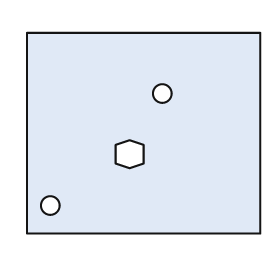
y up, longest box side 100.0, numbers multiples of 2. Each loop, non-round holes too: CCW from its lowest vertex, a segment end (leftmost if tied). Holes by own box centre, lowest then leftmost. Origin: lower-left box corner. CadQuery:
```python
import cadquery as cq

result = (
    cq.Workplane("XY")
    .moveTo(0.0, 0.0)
    .lineTo(100.0, 0.0)
    .lineTo(100.0, 86.0)
    .lineTo(0.0, 86.0)
    .close()
    .moveTo(10.0, 12.0)
    .circle(4.0)
    .moveTo(44.0, 28.0)
    .lineTo(50.0, 30.0)
    .lineTo(50.0, 38.0)
    .lineTo(44.0, 40.0)
    .lineTo(38.0, 38.0)
    .lineTo(38.0, 30.0)
    .close()
    .moveTo(58.0, 60.0)
    .circle(4.0)
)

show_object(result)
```